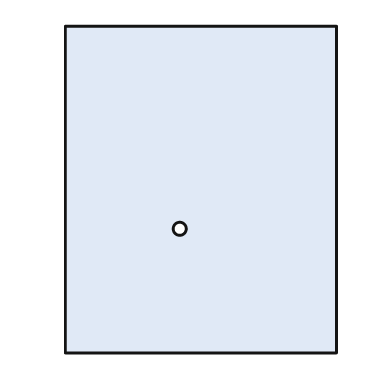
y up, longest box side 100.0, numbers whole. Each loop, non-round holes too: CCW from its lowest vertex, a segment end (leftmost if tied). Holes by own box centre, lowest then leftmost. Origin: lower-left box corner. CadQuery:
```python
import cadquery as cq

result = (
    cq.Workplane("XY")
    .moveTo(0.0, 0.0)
    .lineTo(83.0, 0.0)
    .lineTo(83.0, 100.0)
    .lineTo(0.0, 100.0)
    .close()
    .moveTo(35.0, 38.0)
    .circle(2.0)
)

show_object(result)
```